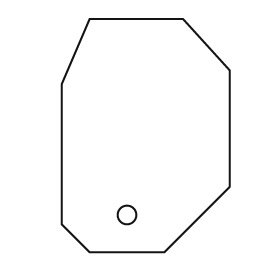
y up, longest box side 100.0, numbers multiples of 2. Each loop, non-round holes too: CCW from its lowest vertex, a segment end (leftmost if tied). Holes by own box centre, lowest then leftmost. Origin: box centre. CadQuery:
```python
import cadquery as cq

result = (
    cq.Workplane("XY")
    .moveTo(-24.0, -50.0)
    .lineTo(8.0, -50.0)
    .lineTo(36.0, -22.0)
    .lineTo(36.0, 28.0)
    .lineTo(16.0, 50.0)
    .lineTo(-24.0, 50.0)
    .lineTo(-36.0, 22.0)
    .lineTo(-36.0, -38.0)
    .close()
    .moveTo(-8.0, -34.0)
    .circle(4.0)
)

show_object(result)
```